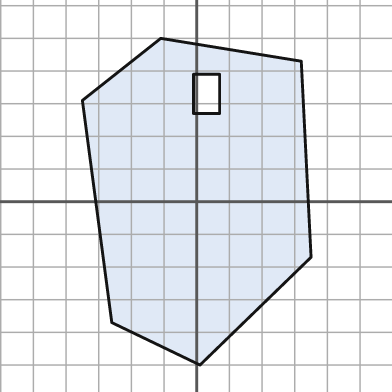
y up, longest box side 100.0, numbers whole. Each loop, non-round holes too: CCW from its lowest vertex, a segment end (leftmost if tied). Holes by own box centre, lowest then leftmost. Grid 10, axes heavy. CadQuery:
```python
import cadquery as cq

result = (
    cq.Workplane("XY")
    .moveTo(1.0, -50.0)
    .lineTo(35.0, -17.0)
    .lineTo(32.0, 43.0)
    .lineTo(-11.0, 50.0)
    .lineTo(-35.0, 31.0)
    .lineTo(-26.0, -37.0)
    .close()
    .moveTo(-1.0, 27.0)
    .lineTo(7.0, 27.0)
    .lineTo(7.0, 39.0)
    .lineTo(-1.0, 39.0)
    .close()
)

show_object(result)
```